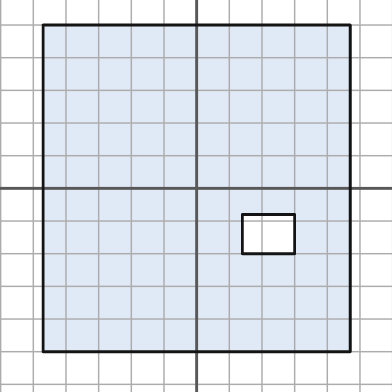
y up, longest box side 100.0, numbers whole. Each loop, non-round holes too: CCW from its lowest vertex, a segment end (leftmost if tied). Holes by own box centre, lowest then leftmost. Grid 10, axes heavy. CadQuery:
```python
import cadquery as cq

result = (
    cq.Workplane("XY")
    .moveTo(-47.0, -50.0)
    .lineTo(47.0, -50.0)
    .lineTo(47.0, 50.0)
    .lineTo(-47.0, 50.0)
    .close()
    .moveTo(14.0, -20.0)
    .lineTo(30.0, -20.0)
    .lineTo(30.0, -8.0)
    .lineTo(14.0, -8.0)
    .close()
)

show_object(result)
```